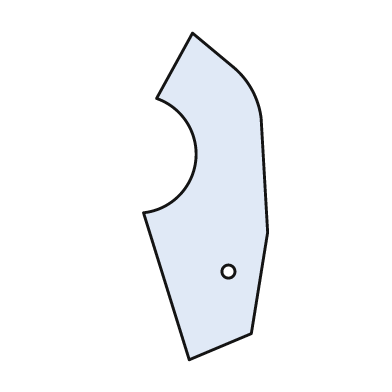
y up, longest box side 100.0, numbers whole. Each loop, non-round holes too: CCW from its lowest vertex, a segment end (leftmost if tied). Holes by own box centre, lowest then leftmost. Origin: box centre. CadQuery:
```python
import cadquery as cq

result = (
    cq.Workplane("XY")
    .moveTo(-5.0, -50.0)
    .lineTo(14.0, -42.0)
    .lineTo(19.0, -11.0)
    .lineTo(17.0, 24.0)
    .threePointArc((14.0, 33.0), (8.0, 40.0))
    .lineTo(-4.0, 50.0)
    .lineTo(-15.0, 30.0)
    .threePointArc((-3.0, 11.0), (-19.0, -5.0))
    .close()
    .moveTo(7.0, -23.0)
    .circle(2.0)
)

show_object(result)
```